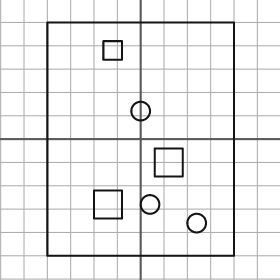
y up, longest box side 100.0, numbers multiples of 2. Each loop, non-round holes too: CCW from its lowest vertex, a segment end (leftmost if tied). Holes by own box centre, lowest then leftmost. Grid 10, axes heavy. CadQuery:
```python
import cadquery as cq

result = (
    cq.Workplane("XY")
    .moveTo(-40.0, -50.0)
    .lineTo(40.0, -50.0)
    .lineTo(40.0, 50.0)
    .lineTo(-40.0, 50.0)
    .close()
    .moveTo(24.0, -36.0)
    .circle(4.0)
    .moveTo(-20.0, -34.0)
    .lineTo(-8.0, -34.0)
    .lineTo(-8.0, -22.0)
    .lineTo(-20.0, -22.0)
    .close()
    .moveTo(4.0, -28.0)
    .circle(4.0)
    .moveTo(6.0, -16.0)
    .lineTo(18.0, -16.0)
    .lineTo(18.0, -4.0)
    .lineTo(6.0, -4.0)
    .close()
    .moveTo(0.0, 12.0)
    .circle(4.0)
    .moveTo(-16.0, 34.0)
    .lineTo(-8.0, 34.0)
    .lineTo(-8.0, 42.0)
    .lineTo(-16.0, 42.0)
    .close()
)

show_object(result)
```